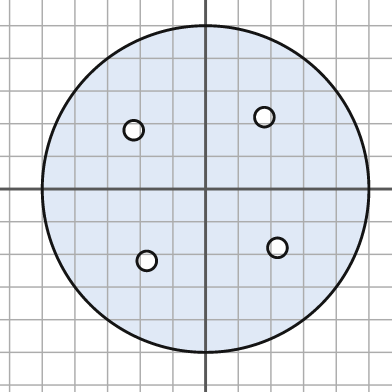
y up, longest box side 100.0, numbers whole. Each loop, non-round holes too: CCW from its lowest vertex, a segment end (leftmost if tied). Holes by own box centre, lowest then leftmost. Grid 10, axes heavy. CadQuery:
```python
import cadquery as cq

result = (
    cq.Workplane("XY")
    .moveTo(0.0, 0.0)
    .circle(50.0)
    .moveTo(-18.0, -22.0)
    .circle(3.0)
    .moveTo(22.0, -18.0)
    .circle(3.0)
    .moveTo(-22.0, 18.0)
    .circle(3.0)
    .moveTo(18.0, 22.0)
    .circle(3.0)
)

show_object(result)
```